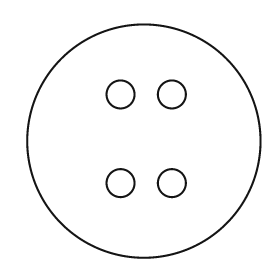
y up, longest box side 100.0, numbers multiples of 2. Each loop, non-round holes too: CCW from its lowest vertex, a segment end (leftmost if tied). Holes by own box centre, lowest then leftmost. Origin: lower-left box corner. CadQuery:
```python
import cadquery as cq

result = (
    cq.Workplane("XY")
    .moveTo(50.0, 50.0)
    .circle(50.0)
    .moveTo(40.0, 32.0)
    .circle(6.0)
    .moveTo(62.0, 32.0)
    .circle(6.0)
    .moveTo(40.0, 70.0)
    .circle(6.0)
    .moveTo(62.0, 70.0)
    .circle(6.0)
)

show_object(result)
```